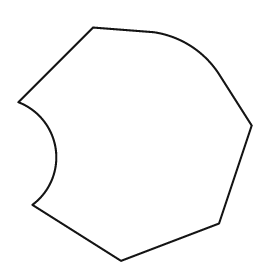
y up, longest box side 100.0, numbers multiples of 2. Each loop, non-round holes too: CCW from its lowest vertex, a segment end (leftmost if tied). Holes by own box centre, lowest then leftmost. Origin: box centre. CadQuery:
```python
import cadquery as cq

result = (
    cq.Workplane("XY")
    .moveTo(-6.0, -50.0)
    .lineTo(36.0, -34.0)
    .lineTo(50.0, 8.0)
    .lineTo(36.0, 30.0)
    .threePointArc((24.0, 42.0), (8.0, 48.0))
    .lineTo(-18.0, 50.0)
    .lineTo(-50.0, 18.0)
    .threePointArc((-34.0, -2.0), (-44.0, -26.0))
    .close()
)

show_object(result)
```